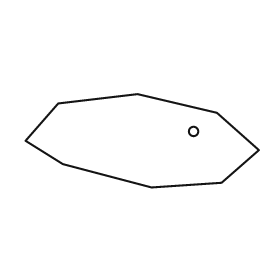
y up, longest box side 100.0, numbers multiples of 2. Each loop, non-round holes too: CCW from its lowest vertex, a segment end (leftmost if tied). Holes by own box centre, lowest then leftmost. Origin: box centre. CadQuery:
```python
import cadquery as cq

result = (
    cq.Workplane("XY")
    .moveTo(4.0, -20.0)
    .lineTo(34.0, -18.0)
    .lineTo(50.0, -4.0)
    .lineTo(32.0, 12.0)
    .lineTo(-2.0, 20.0)
    .lineTo(-36.0, 16.0)
    .lineTo(-50.0, 0.0)
    .lineTo(-34.0, -10.0)
    .close()
    .moveTo(22.0, 4.0)
    .circle(2.0)
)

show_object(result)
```